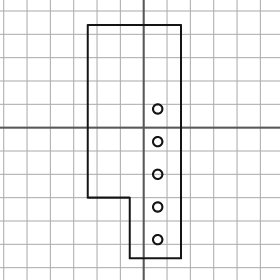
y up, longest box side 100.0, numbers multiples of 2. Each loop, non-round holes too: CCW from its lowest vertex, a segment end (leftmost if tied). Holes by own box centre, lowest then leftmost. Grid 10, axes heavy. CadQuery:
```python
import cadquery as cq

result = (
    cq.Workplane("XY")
    .moveTo(-6.0, -56.0)
    .lineTo(16.0, -56.0)
    .lineTo(16.0, 44.0)
    .lineTo(-24.0, 44.0)
    .lineTo(-24.0, -30.0)
    .lineTo(-6.0, -30.0)
    .close()
    .moveTo(6.0, -48.0)
    .circle(2.0)
    .moveTo(6.0, -34.0)
    .circle(2.0)
    .moveTo(6.0, -20.0)
    .circle(2.0)
    .moveTo(6.0, -6.0)
    .circle(2.0)
    .moveTo(6.0, 8.0)
    .circle(2.0)
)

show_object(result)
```